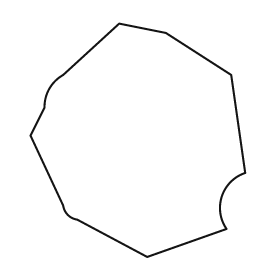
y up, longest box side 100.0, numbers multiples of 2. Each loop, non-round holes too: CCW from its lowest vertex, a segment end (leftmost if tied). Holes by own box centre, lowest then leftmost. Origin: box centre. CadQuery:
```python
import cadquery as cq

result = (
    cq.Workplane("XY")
    .moveTo(4.0, -50.0)
    .lineTo(38.0, -38.0)
    .threePointArc((36.0, -24.0), (46.0, -14.0))
    .lineTo(40.0, 28.0)
    .lineTo(12.0, 46.0)
    .lineTo(-8.0, 50.0)
    .lineTo(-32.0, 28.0)
    .threePointArc((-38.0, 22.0), (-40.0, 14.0))
    .lineTo(-46.0, 2.0)
    .lineTo(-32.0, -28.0)
    .threePointArc((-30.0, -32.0), (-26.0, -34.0))
    .close()
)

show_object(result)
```